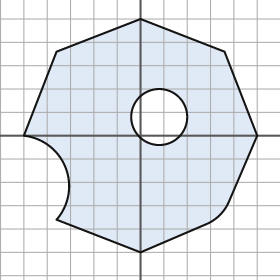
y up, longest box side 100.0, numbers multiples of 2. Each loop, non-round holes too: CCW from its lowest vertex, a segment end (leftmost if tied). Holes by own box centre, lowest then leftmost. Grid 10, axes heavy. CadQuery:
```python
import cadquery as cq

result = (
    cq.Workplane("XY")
    .moveTo(0.0, -50.0)
    .lineTo(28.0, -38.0)
    .threePointArc((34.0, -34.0), (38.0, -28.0))
    .lineTo(50.0, 0.0)
    .lineTo(36.0, 36.0)
    .lineTo(0.0, 50.0)
    .lineTo(-36.0, 36.0)
    .lineTo(-50.0, 0.0)
    .threePointArc((-32.0, -14.0), (-36.0, -36.0))
    .close()
    .moveTo(8.0, 8.0)
    .circle(12.0)
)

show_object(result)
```